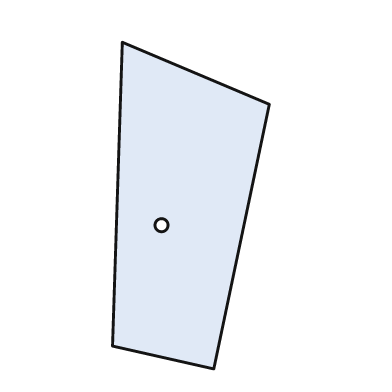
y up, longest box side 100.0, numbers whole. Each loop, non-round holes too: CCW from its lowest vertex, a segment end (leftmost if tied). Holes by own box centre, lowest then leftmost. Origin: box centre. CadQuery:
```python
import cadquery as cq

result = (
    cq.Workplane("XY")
    .moveTo(7.0, -50.0)
    .lineTo(24.0, 31.0)
    .lineTo(-21.0, 50.0)
    .lineTo(-24.0, -43.0)
    .close()
    .moveTo(-9.0, -6.0)
    .circle(2.0)
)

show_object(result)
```